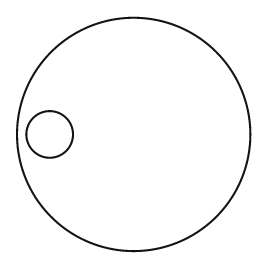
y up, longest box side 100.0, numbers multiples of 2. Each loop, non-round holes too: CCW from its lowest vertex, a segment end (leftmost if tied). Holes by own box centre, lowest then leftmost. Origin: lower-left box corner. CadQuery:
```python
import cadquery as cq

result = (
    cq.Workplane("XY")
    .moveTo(50.0, 50.0)
    .circle(50.0)
    .moveTo(14.0, 50.0)
    .circle(10.0)
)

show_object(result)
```